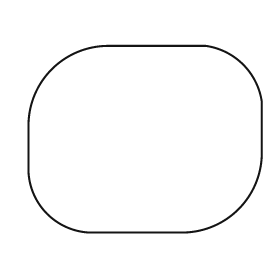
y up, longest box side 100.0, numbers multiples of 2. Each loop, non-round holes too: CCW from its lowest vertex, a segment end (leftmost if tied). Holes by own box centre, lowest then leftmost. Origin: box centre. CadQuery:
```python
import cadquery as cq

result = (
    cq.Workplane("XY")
    .moveTo(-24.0, -40.0)
    .lineTo(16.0, -40.0)
    .threePointArc((40.0, -30.0), (50.0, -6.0))
    .lineTo(50.0, 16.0)
    .threePointArc((42.0, 32.0), (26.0, 40.0))
    .lineTo(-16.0, 40.0)
    .threePointArc((-40.0, 30.0), (-50.0, 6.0))
    .lineTo(-50.0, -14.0)
    .threePointArc((-42.0, -32.0), (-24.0, -40.0))
    .close()
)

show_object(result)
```